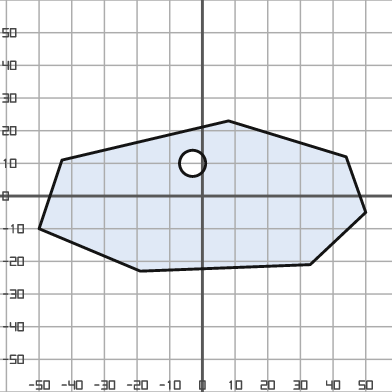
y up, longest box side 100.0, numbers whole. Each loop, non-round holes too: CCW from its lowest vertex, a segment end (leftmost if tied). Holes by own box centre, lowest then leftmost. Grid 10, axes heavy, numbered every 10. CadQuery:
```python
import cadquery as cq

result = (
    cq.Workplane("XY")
    .moveTo(-19.0, -23.0)
    .lineTo(33.0, -21.0)
    .lineTo(50.0, -5.0)
    .lineTo(44.0, 12.0)
    .lineTo(8.0, 23.0)
    .lineTo(-43.0, 11.0)
    .lineTo(-50.0, -10.0)
    .close()
    .moveTo(-3.0, 10.0)
    .circle(4.0)
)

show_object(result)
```